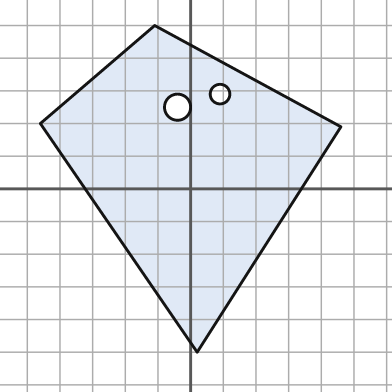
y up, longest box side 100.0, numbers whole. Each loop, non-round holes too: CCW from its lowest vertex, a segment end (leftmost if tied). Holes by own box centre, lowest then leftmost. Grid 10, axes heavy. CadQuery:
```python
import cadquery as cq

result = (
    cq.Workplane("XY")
    .moveTo(2.0, -50.0)
    .lineTo(46.0, 19.0)
    .lineTo(-11.0, 50.0)
    .lineTo(-46.0, 20.0)
    .close()
    .moveTo(-4.0, 25.0)
    .circle(4.0)
    .moveTo(9.0, 29.0)
    .circle(3.0)
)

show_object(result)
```